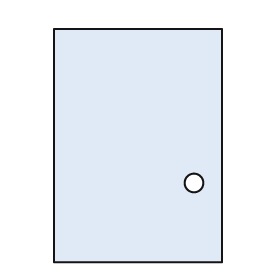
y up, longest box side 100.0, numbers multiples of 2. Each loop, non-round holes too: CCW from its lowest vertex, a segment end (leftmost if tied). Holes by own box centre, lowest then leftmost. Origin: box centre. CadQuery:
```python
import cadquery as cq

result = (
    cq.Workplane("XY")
    .moveTo(-36.0, -50.0)
    .lineTo(36.0, -50.0)
    .lineTo(36.0, 50.0)
    .lineTo(-36.0, 50.0)
    .close()
    .moveTo(24.0, -16.0)
    .circle(4.0)
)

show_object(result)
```